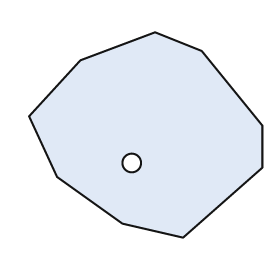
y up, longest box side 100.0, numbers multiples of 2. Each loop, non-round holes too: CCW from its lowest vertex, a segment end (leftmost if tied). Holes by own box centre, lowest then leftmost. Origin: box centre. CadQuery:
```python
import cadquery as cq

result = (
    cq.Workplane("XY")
    .moveTo(16.0, -44.0)
    .lineTo(50.0, -14.0)
    .lineTo(50.0, 4.0)
    .lineTo(24.0, 36.0)
    .lineTo(4.0, 44.0)
    .lineTo(-28.0, 32.0)
    .lineTo(-50.0, 8.0)
    .lineTo(-38.0, -18.0)
    .lineTo(-10.0, -38.0)
    .close()
    .moveTo(-6.0, -12.0)
    .circle(4.0)
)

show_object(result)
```